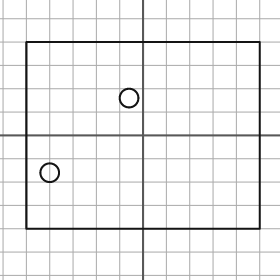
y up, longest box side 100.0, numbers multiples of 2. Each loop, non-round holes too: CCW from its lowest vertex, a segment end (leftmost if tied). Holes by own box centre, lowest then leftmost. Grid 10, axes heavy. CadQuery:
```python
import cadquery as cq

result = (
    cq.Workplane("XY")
    .moveTo(-50.0, -40.0)
    .lineTo(50.0, -40.0)
    .lineTo(50.0, 40.0)
    .lineTo(-50.0, 40.0)
    .close()
    .moveTo(-40.0, -16.0)
    .circle(4.0)
    .moveTo(-6.0, 16.0)
    .circle(4.0)
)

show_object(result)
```